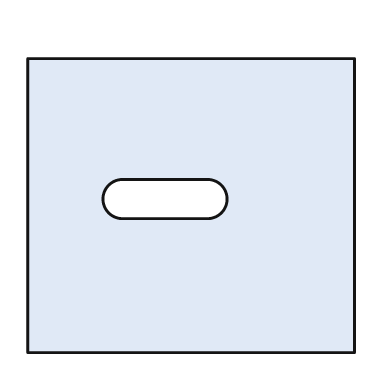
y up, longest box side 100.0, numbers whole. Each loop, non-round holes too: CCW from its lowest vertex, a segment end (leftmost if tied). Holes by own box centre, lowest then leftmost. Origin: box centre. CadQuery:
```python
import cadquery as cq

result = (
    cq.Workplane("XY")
    .moveTo(-50.0, -45.0)
    .lineTo(50.0, -45.0)
    .lineTo(50.0, 45.0)
    .lineTo(-50.0, 45.0)
    .close()
    .moveTo(-21.0, -4.0)
    .lineTo(5.0, -4.0)
    .threePointArc((11.0, 2.0), (5.0, 8.0))
    .lineTo(-21.0, 8.0)
    .threePointArc((-27.0, 2.0), (-21.0, -4.0))
    .close()
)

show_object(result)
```